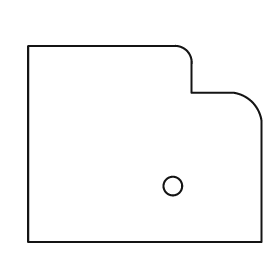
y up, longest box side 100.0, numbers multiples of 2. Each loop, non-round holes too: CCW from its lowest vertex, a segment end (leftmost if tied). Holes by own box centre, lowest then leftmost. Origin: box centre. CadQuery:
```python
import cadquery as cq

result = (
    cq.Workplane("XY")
    .moveTo(-50.0, -42.0)
    .lineTo(50.0, -42.0)
    .lineTo(50.0, 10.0)
    .threePointArc((46.0, 18.0), (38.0, 22.0))
    .lineTo(20.0, 22.0)
    .lineTo(20.0, 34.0)
    .threePointArc((18.0, 40.0), (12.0, 42.0))
    .lineTo(-50.0, 42.0)
    .close()
    .moveTo(12.0, -18.0)
    .circle(4.0)
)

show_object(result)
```